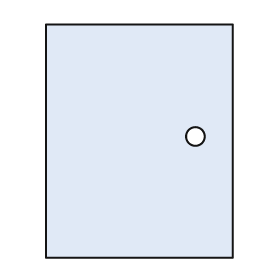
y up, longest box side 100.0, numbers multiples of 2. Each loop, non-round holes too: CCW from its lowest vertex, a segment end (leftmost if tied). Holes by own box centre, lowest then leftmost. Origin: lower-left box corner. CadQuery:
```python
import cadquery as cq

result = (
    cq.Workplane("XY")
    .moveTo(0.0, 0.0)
    .lineTo(80.0, 0.0)
    .lineTo(80.0, 100.0)
    .lineTo(0.0, 100.0)
    .close()
    .moveTo(64.0, 52.0)
    .circle(4.0)
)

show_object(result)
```